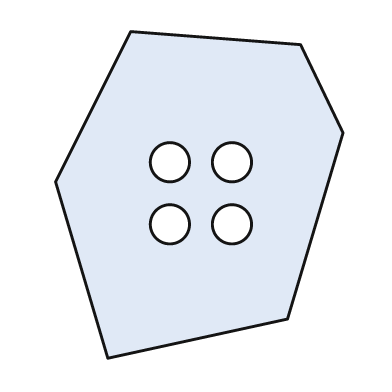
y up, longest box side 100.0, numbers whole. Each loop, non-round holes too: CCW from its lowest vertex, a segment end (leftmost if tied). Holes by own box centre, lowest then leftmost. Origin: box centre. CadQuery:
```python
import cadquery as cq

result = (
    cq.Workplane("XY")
    .moveTo(-28.0, -50.0)
    .lineTo(27.0, -38.0)
    .lineTo(44.0, 19.0)
    .lineTo(31.0, 46.0)
    .lineTo(-21.0, 50.0)
    .lineTo(-44.0, 4.0)
    .close()
    .moveTo(-9.0, -9.0)
    .circle(6.0)
    .moveTo(10.0, -9.0)
    .circle(6.0)
    .moveTo(-9.0, 10.0)
    .circle(6.0)
    .moveTo(10.0, 10.0)
    .circle(6.0)
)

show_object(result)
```